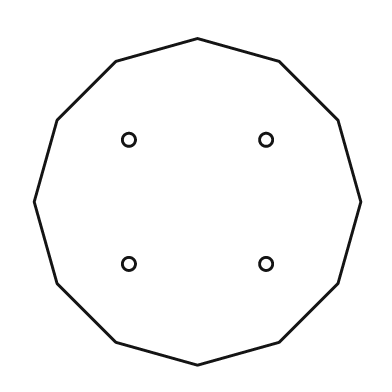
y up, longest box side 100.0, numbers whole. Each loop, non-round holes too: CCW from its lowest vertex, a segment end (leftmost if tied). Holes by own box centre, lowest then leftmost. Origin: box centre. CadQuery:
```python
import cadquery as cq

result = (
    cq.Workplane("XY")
    .moveTo(0.0, -50.0)
    .lineTo(25.0, -43.0)
    .lineTo(43.0, -25.0)
    .lineTo(50.0, 0.0)
    .lineTo(43.0, 25.0)
    .lineTo(25.0, 43.0)
    .lineTo(0.0, 50.0)
    .lineTo(-25.0, 43.0)
    .lineTo(-43.0, 25.0)
    .lineTo(-50.0, 0.0)
    .lineTo(-43.0, -25.0)
    .lineTo(-25.0, -43.0)
    .close()
    .moveTo(-21.0, -19.0)
    .circle(2.0)
    .moveTo(21.0, -19.0)
    .circle(2.0)
    .moveTo(-21.0, 19.0)
    .circle(2.0)
    .moveTo(21.0, 19.0)
    .circle(2.0)
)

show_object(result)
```